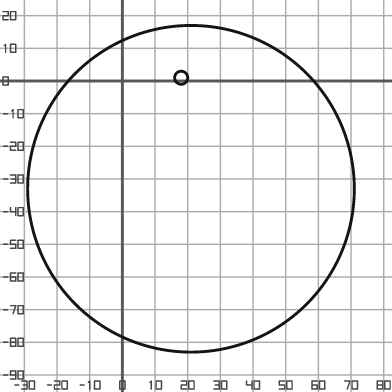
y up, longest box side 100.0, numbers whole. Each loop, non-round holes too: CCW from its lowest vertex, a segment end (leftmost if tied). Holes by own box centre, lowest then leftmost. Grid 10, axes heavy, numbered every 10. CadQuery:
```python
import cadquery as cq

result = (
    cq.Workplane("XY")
    .moveTo(21.0, -33.0)
    .circle(50.0)
    .moveTo(18.0, 1.0)
    .circle(2.0)
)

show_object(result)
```